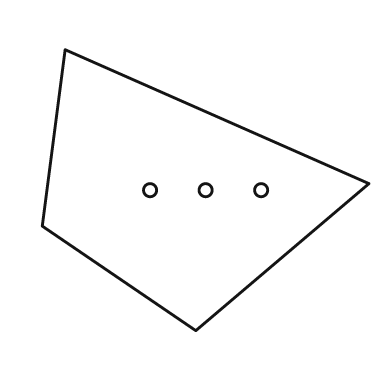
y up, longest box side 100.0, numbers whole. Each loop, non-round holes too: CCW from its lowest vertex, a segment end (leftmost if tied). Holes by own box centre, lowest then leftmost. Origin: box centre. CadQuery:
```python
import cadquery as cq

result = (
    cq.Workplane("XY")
    .moveTo(-3.0, -43.0)
    .lineTo(50.0, 2.0)
    .lineTo(-43.0, 43.0)
    .lineTo(-50.0, -11.0)
    .close()
    .moveTo(-17.0, 0.0)
    .circle(2.0)
    .moveTo(0.0, 0.0)
    .circle(2.0)
    .moveTo(17.0, 0.0)
    .circle(2.0)
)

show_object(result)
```